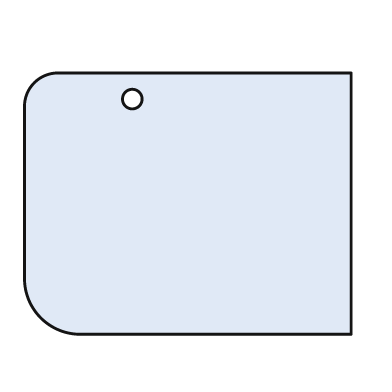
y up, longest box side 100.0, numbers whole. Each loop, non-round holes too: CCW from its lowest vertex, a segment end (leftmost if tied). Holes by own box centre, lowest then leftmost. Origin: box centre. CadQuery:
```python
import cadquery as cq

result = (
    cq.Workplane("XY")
    .moveTo(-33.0, -40.0)
    .lineTo(50.0, -40.0)
    .lineTo(50.0, 40.0)
    .lineTo(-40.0, 40.0)
    .threePointArc((-47.0, 37.0), (-50.0, 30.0))
    .lineTo(-50.0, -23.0)
    .threePointArc((-45.0, -35.0), (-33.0, -40.0))
    .close()
    .moveTo(-17.0, 32.0)
    .circle(3.0)
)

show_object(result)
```